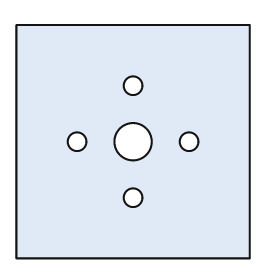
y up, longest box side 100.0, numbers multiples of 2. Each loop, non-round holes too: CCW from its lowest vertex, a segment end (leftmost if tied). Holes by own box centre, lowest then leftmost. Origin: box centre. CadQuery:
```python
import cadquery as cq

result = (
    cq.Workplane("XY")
    .moveTo(-50.0, -50.0)
    .lineTo(50.0, -50.0)
    .lineTo(50.0, 50.0)
    .lineTo(-50.0, 50.0)
    .close()
    .moveTo(0.0, -24.0)
    .circle(4.0)
    .moveTo(-24.0, 0.0)
    .circle(4.0)
    .moveTo(0.0, 0.0)
    .circle(8.0)
    .moveTo(24.0, 0.0)
    .circle(4.0)
    .moveTo(0.0, 24.0)
    .circle(4.0)
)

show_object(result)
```